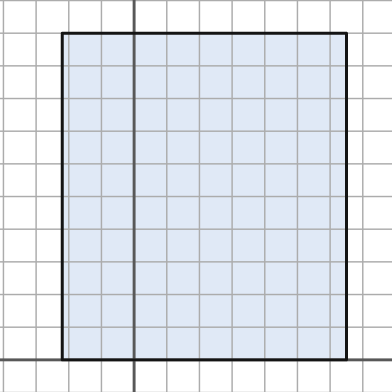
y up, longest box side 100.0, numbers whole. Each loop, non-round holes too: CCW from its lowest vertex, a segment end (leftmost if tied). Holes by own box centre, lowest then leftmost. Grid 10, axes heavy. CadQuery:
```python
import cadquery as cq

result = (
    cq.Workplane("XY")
    .moveTo(-22.0, 0.0)
    .lineTo(65.0, 0.0)
    .lineTo(65.0, 100.0)
    .lineTo(-22.0, 100.0)
    .close()
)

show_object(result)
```